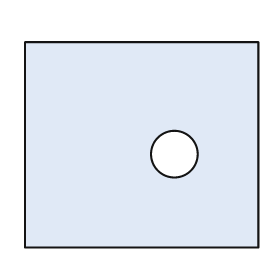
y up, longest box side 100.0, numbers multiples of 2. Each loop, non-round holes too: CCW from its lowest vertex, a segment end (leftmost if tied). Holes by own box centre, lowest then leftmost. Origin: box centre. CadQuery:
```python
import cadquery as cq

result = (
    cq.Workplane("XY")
    .moveTo(-50.0, -44.0)
    .lineTo(50.0, -44.0)
    .lineTo(50.0, 44.0)
    .lineTo(-50.0, 44.0)
    .close()
    .moveTo(14.0, -4.0)
    .circle(10.0)
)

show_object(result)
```